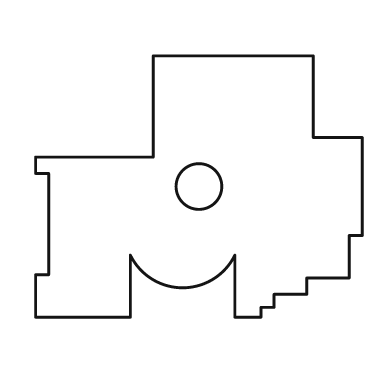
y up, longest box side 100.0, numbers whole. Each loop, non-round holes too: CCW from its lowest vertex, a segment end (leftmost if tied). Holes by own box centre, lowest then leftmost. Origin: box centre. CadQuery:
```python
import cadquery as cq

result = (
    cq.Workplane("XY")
    .moveTo(-50.0, -40.0)
    .lineTo(-21.0, -40.0)
    .lineTo(-21.0, -21.0)
    .threePointArc((-5.0, -31.0), (11.0, -21.0))
    .lineTo(11.0, -40.0)
    .lineTo(19.0, -40.0)
    .lineTo(19.0, -37.0)
    .lineTo(23.0, -37.0)
    .lineTo(23.0, -33.0)
    .lineTo(33.0, -33.0)
    .lineTo(33.0, -28.0)
    .lineTo(46.0, -28.0)
    .lineTo(46.0, -15.0)
    .lineTo(50.0, -15.0)
    .lineTo(50.0, 15.0)
    .lineTo(35.0, 15.0)
    .lineTo(35.0, 40.0)
    .lineTo(-14.0, 40.0)
    .lineTo(-14.0, 9.0)
    .lineTo(-50.0, 9.0)
    .lineTo(-50.0, 4.0)
    .lineTo(-46.0, 4.0)
    .lineTo(-46.0, -27.0)
    .lineTo(-50.0, -27.0)
    .close()
    .moveTo(0.0, 0.0)
    .circle(7.0)
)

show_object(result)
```